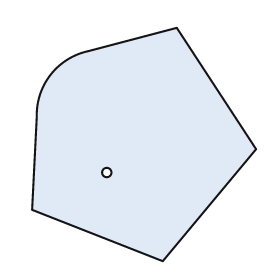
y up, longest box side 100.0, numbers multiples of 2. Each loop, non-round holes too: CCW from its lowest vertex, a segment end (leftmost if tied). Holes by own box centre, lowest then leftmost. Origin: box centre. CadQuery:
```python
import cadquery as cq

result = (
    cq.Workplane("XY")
    .moveTo(8.0, -50.0)
    .lineTo(48.0, -2.0)
    .lineTo(14.0, 50.0)
    .lineTo(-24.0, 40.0)
    .threePointArc((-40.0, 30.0), (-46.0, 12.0))
    .lineTo(-48.0, -28.0)
    .close()
    .moveTo(-16.0, -12.0)
    .circle(2.0)
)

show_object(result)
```